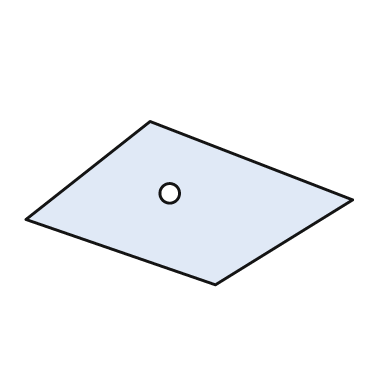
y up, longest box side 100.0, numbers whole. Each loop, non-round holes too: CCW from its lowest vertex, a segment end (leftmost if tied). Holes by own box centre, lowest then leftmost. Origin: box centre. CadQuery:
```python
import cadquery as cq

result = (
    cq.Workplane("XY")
    .moveTo(8.0, -25.0)
    .lineTo(50.0, 1.0)
    .lineTo(-12.0, 25.0)
    .lineTo(-50.0, -5.0)
    .close()
    .moveTo(-6.0, 3.0)
    .circle(3.0)
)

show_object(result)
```